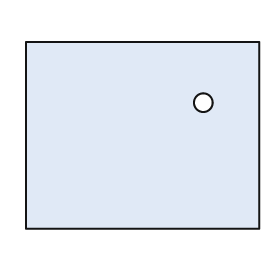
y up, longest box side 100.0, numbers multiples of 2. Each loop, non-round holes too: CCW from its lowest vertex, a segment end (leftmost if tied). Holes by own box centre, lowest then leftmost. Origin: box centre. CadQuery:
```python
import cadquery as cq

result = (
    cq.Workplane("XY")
    .moveTo(-50.0, -40.0)
    .lineTo(50.0, -40.0)
    .lineTo(50.0, 40.0)
    .lineTo(-50.0, 40.0)
    .close()
    .moveTo(26.0, 14.0)
    .circle(4.0)
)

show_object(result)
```